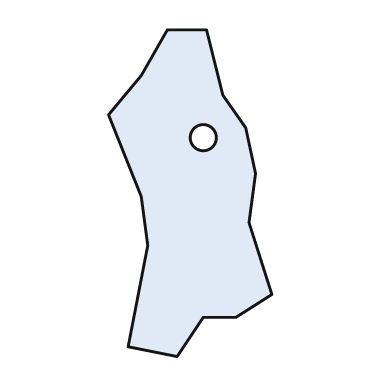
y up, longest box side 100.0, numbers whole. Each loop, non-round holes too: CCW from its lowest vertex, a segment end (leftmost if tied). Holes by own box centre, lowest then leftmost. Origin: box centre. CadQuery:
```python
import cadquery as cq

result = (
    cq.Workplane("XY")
    .moveTo(-4.0, -50.0)
    .lineTo(4.0, -38.0)
    .lineTo(14.0, -38.0)
    .lineTo(25.0, -31.0)
    .lineTo(18.0, -9.0)
    .lineTo(20.0, 6.0)
    .lineTo(17.0, 20.0)
    .lineTo(10.0, 30.0)
    .lineTo(5.0, 50.0)
    .lineTo(-7.0, 50.0)
    .lineTo(-15.0, 36.0)
    .lineTo(-25.0, 24.0)
    .lineTo(-15.0, -1.0)
    .lineTo(-13.0, -16.0)
    .lineTo(-19.0, -47.0)
    .close()
    .moveTo(4.0, 17.0)
    .circle(4.0)
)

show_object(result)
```